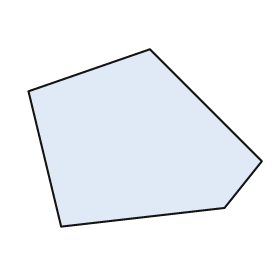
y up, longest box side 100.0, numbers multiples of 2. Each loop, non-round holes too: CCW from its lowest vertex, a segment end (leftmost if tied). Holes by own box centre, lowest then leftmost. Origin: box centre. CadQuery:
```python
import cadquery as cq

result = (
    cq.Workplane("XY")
    .moveTo(-36.0, -38.0)
    .lineTo(34.0, -30.0)
    .lineTo(50.0, -10.0)
    .lineTo(2.0, 38.0)
    .lineTo(-50.0, 20.0)
    .close()
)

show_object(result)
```